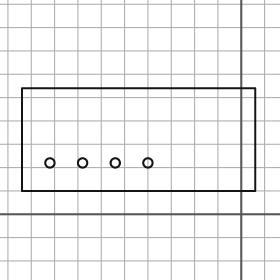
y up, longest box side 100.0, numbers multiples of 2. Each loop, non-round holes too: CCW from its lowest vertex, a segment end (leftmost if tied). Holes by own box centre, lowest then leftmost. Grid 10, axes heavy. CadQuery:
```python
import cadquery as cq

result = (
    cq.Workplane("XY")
    .moveTo(-94.0, 10.0)
    .lineTo(6.0, 10.0)
    .lineTo(6.0, 54.0)
    .lineTo(-94.0, 54.0)
    .close()
    .moveTo(-82.0, 22.0)
    .circle(2.0)
    .moveTo(-68.0, 22.0)
    .circle(2.0)
    .moveTo(-54.0, 22.0)
    .circle(2.0)
    .moveTo(-40.0, 22.0)
    .circle(2.0)
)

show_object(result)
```